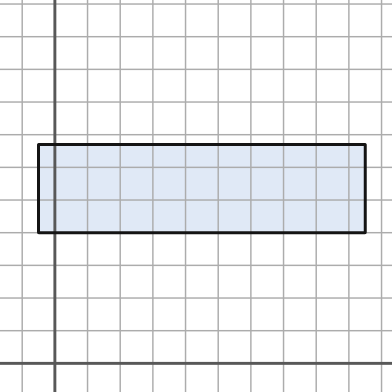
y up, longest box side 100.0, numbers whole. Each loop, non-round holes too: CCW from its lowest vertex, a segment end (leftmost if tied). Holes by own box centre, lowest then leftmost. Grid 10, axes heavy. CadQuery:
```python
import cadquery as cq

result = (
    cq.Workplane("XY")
    .moveTo(-5.0, 40.0)
    .lineTo(95.0, 40.0)
    .lineTo(95.0, 67.0)
    .lineTo(-5.0, 67.0)
    .close()
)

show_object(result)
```